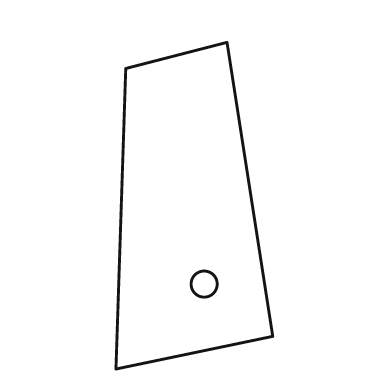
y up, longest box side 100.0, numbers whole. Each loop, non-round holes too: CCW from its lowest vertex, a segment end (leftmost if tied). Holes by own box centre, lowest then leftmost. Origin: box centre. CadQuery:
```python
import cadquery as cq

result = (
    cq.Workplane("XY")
    .moveTo(-24.0, -50.0)
    .lineTo(24.0, -40.0)
    .lineTo(10.0, 50.0)
    .lineTo(-21.0, 42.0)
    .close()
    .moveTo(3.0, -24.0)
    .circle(4.0)
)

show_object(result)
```